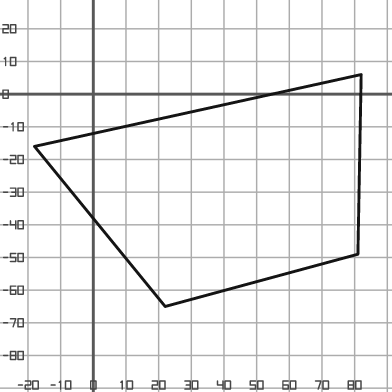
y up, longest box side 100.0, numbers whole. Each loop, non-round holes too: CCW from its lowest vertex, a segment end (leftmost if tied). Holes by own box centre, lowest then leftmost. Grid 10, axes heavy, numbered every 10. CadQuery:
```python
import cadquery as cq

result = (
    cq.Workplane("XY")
    .moveTo(22.0, -65.0)
    .lineTo(81.0, -49.0)
    .lineTo(82.0, 6.0)
    .lineTo(-18.0, -16.0)
    .close()
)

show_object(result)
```